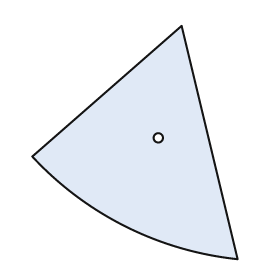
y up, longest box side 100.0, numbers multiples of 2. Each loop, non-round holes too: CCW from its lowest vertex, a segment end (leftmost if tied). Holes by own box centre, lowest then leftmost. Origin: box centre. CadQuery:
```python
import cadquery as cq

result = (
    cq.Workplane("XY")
    .moveTo(44.0, -50.0)
    .lineTo(20.0, 50.0)
    .lineTo(-44.0, -6.0)
    .threePointArc((-4.0, -36.0), (44.0, -50.0))
    .close()
    .moveTo(10.0, 2.0)
    .circle(2.0)
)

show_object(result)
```